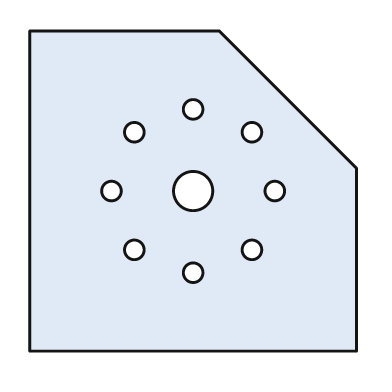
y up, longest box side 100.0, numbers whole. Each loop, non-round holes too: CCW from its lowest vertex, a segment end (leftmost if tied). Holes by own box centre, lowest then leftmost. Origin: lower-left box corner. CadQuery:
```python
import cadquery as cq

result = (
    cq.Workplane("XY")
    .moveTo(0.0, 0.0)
    .lineTo(100.0, 0.0)
    .lineTo(100.0, 56.0)
    .lineTo(58.0, 98.0)
    .lineTo(0.0, 98.0)
    .close()
    .moveTo(50.0, 24.0)
    .circle(3.0)
    .moveTo(32.0, 31.0)
    .circle(3.0)
    .moveTo(68.0, 31.0)
    .circle(3.0)
    .moveTo(25.0, 49.0)
    .circle(3.0)
    .moveTo(50.0, 49.0)
    .circle(6.0)
    .moveTo(75.0, 49.0)
    .circle(3.0)
    .moveTo(32.0, 67.0)
    .circle(3.0)
    .moveTo(68.0, 67.0)
    .circle(3.0)
    .moveTo(50.0, 74.0)
    .circle(3.0)
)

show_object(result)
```